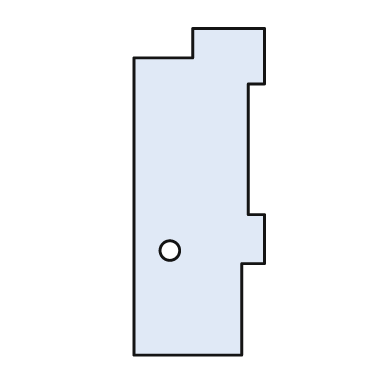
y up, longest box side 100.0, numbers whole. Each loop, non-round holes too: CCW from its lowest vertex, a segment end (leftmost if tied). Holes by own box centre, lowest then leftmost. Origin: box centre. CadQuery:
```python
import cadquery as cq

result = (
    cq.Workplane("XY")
    .moveTo(-20.0, -50.0)
    .lineTo(13.0, -50.0)
    .lineTo(13.0, -22.0)
    .lineTo(20.0, -22.0)
    .lineTo(20.0, -7.0)
    .lineTo(15.0, -7.0)
    .lineTo(15.0, 33.0)
    .lineTo(20.0, 33.0)
    .lineTo(20.0, 50.0)
    .lineTo(-2.0, 50.0)
    .lineTo(-2.0, 41.0)
    .lineTo(-20.0, 41.0)
    .close()
    .moveTo(-9.0, -18.0)
    .circle(3.0)
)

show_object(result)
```